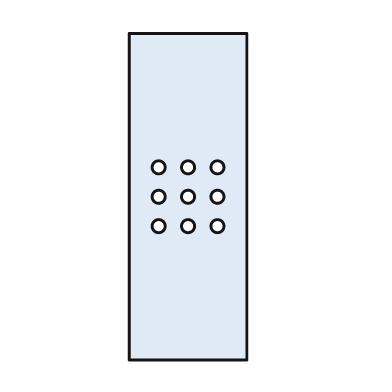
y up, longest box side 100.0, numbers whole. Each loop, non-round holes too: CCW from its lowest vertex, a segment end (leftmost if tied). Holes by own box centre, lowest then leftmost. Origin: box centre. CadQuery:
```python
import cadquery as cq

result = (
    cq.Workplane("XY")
    .moveTo(-18.0, -50.0)
    .lineTo(18.0, -50.0)
    .lineTo(18.0, 50.0)
    .lineTo(-18.0, 50.0)
    .close()
    .moveTo(-9.0, -9.0)
    .circle(2.0)
    .moveTo(0.0, -9.0)
    .circle(2.0)
    .moveTo(9.0, -9.0)
    .circle(2.0)
    .moveTo(-9.0, 0.0)
    .circle(2.0)
    .moveTo(0.0, 0.0)
    .circle(2.0)
    .moveTo(9.0, 0.0)
    .circle(2.0)
    .moveTo(-9.0, 9.0)
    .circle(2.0)
    .moveTo(0.0, 9.0)
    .circle(2.0)
    .moveTo(9.0, 9.0)
    .circle(2.0)
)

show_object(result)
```